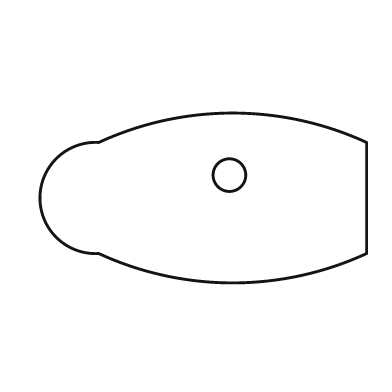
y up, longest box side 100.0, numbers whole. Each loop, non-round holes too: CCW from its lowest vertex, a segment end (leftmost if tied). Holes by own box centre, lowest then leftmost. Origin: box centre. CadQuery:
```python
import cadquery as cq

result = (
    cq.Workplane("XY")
    .moveTo(-32.0, -17.0)
    .threePointArc((9.0, -26.0), (50.0, -17.0))
    .lineTo(50.0, 17.0)
    .threePointArc((9.0, 26.0), (-32.0, 17.0))
    .threePointArc((-50.0, 0.0), (-32.0, -17.0))
    .close()
    .moveTo(8.0, 7.0)
    .circle(5.0)
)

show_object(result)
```